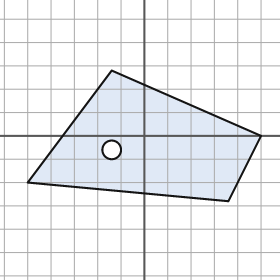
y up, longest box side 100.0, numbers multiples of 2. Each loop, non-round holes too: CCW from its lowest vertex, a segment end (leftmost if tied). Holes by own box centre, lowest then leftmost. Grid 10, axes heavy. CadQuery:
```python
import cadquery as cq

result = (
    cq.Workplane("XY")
    .moveTo(36.0, -28.0)
    .lineTo(50.0, 0.0)
    .lineTo(-14.0, 28.0)
    .lineTo(-50.0, -20.0)
    .close()
    .moveTo(-14.0, -6.0)
    .circle(4.0)
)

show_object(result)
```